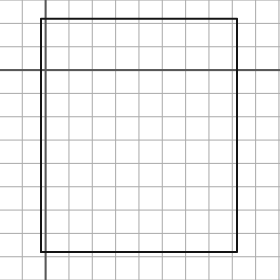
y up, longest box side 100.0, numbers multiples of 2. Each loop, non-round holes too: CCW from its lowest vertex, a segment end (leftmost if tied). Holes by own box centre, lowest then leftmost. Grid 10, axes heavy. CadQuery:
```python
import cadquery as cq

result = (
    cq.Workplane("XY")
    .moveTo(-2.0, -78.0)
    .lineTo(82.0, -78.0)
    .lineTo(82.0, 22.0)
    .lineTo(-2.0, 22.0)
    .close()
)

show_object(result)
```